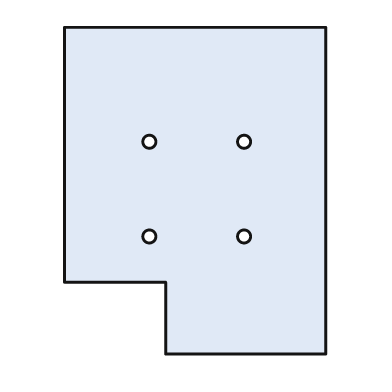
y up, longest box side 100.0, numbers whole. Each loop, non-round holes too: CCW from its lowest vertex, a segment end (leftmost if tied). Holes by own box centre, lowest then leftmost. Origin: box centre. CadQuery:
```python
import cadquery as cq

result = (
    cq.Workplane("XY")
    .moveTo(-9.0, -50.0)
    .lineTo(40.0, -50.0)
    .lineTo(40.0, 50.0)
    .lineTo(-40.0, 50.0)
    .lineTo(-40.0, -28.0)
    .lineTo(-9.0, -28.0)
    .close()
    .moveTo(-14.0, -14.0)
    .circle(2.0)
    .moveTo(15.0, -14.0)
    .circle(2.0)
    .moveTo(-14.0, 15.0)
    .circle(2.0)
    .moveTo(15.0, 15.0)
    .circle(2.0)
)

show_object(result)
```